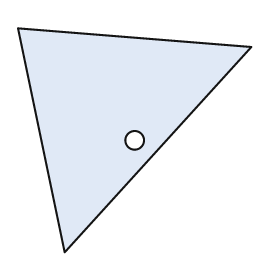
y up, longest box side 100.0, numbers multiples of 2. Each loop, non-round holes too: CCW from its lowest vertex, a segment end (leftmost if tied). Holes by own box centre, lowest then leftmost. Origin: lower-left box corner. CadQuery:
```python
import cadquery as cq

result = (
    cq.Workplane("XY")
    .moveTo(20.0, 0.0)
    .lineTo(100.0, 88.0)
    .lineTo(0.0, 96.0)
    .close()
    .moveTo(50.0, 48.0)
    .circle(4.0)
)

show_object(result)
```